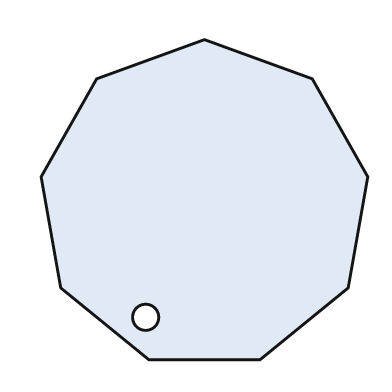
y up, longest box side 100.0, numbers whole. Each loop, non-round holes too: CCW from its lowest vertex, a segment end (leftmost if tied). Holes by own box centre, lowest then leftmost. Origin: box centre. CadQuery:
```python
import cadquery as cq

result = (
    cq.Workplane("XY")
    .moveTo(-17.0, -49.0)
    .lineTo(17.0, -49.0)
    .lineTo(44.0, -27.0)
    .lineTo(50.0, 7.0)
    .lineTo(33.0, 37.0)
    .lineTo(0.0, 49.0)
    .lineTo(-33.0, 37.0)
    .lineTo(-50.0, 7.0)
    .lineTo(-44.0, -27.0)
    .close()
    .moveTo(-18.0, -36.0)
    .circle(4.0)
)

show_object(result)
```